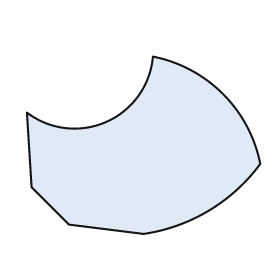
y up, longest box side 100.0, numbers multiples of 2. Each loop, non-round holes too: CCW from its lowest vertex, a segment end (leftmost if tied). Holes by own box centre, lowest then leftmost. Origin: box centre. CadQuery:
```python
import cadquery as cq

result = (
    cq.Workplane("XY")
    .moveTo(0.0, -38.0)
    .threePointArc((28.0, -28.0), (50.0, -8.0))
    .threePointArc((34.0, 22.0), (4.0, 38.0))
    .threePointArc((-16.0, 10.0), (-50.0, 14.0))
    .lineTo(-48.0, -18.0)
    .lineTo(-32.0, -34.0)
    .close()
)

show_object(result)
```